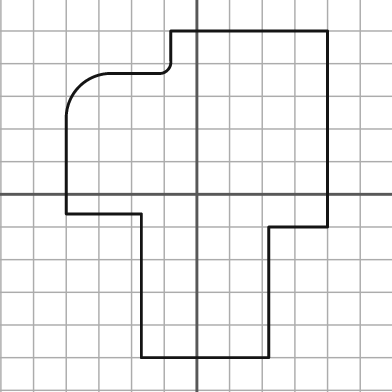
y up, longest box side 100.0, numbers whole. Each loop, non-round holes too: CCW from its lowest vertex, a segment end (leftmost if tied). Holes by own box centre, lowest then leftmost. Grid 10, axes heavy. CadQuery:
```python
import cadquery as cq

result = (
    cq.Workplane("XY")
    .moveTo(-17.0, -50.0)
    .lineTo(22.0, -50.0)
    .lineTo(22.0, -10.0)
    .lineTo(40.0, -10.0)
    .lineTo(40.0, 50.0)
    .lineTo(-8.0, 50.0)
    .lineTo(-8.0, 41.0)
    .threePointArc((-9.0, 38.0), (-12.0, 37.0))
    .lineTo(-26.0, 37.0)
    .threePointArc((-36.0, 33.0), (-40.0, 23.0))
    .lineTo(-40.0, -6.0)
    .lineTo(-17.0, -6.0)
    .close()
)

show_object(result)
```